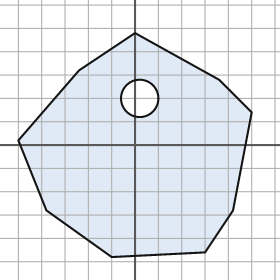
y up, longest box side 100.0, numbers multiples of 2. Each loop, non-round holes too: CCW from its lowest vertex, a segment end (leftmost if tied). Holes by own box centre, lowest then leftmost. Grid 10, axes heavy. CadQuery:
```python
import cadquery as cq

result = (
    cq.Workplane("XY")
    .moveTo(-10.0, -48.0)
    .lineTo(30.0, -46.0)
    .lineTo(42.0, -28.0)
    .lineTo(50.0, 14.0)
    .lineTo(36.0, 28.0)
    .lineTo(0.0, 48.0)
    .lineTo(-24.0, 32.0)
    .lineTo(-50.0, 2.0)
    .lineTo(-38.0, -28.0)
    .close()
    .moveTo(2.0, 20.0)
    .circle(8.0)
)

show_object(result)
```